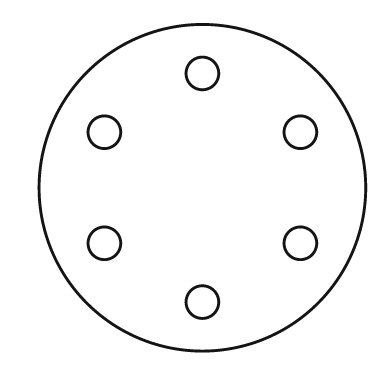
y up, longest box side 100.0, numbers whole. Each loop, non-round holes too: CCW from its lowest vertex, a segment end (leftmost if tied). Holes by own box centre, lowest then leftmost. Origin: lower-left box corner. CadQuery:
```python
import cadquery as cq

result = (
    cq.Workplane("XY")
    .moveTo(50.0, 50.0)
    .circle(50.0)
    .moveTo(50.0, 15.0)
    .circle(5.0)
    .moveTo(20.0, 33.0)
    .circle(5.0)
    .moveTo(80.0, 33.0)
    .circle(5.0)
    .moveTo(20.0, 67.0)
    .circle(5.0)
    .moveTo(80.0, 67.0)
    .circle(5.0)
    .moveTo(50.0, 85.0)
    .circle(5.0)
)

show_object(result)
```